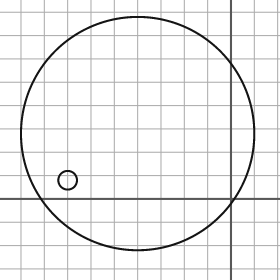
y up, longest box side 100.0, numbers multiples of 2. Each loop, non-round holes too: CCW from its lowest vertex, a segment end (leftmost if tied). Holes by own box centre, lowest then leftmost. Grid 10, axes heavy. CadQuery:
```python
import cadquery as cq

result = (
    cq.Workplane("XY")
    .moveTo(-40.0, 28.0)
    .circle(50.0)
    .moveTo(-70.0, 8.0)
    .circle(4.0)
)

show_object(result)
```